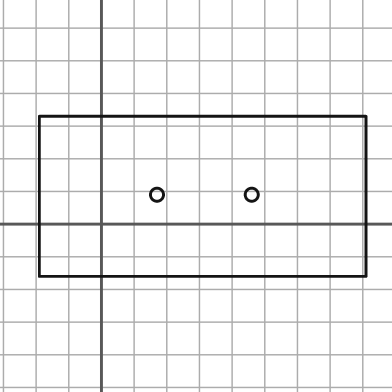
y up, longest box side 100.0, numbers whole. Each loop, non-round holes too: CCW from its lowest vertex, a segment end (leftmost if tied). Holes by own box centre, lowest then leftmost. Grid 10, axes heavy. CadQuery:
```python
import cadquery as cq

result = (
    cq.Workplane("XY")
    .moveTo(-19.0, -16.0)
    .lineTo(81.0, -16.0)
    .lineTo(81.0, 33.0)
    .lineTo(-19.0, 33.0)
    .close()
    .moveTo(17.0, 9.0)
    .circle(2.0)
    .moveTo(46.0, 9.0)
    .circle(2.0)
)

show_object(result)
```